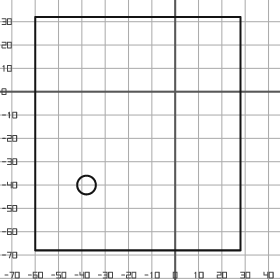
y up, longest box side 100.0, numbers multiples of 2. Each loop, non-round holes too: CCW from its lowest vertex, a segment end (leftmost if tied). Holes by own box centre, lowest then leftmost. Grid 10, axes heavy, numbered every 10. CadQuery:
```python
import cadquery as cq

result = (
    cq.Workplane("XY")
    .moveTo(-60.0, -68.0)
    .lineTo(28.0, -68.0)
    .lineTo(28.0, 32.0)
    .lineTo(-60.0, 32.0)
    .close()
    .moveTo(-38.0, -40.0)
    .circle(4.0)
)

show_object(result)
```